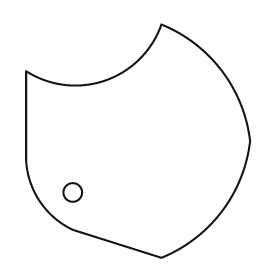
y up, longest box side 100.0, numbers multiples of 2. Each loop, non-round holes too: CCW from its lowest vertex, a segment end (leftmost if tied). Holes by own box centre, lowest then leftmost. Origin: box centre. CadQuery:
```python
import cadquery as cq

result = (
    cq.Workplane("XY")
    .moveTo(10.0, -50.0)
    .threePointArc((36.0, -30.0), (48.0, 0.0))
    .threePointArc((36.0, 30.0), (10.0, 50.0))
    .threePointArc((-14.0, 26.0), (-48.0, 30.0))
    .lineTo(-48.0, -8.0)
    .threePointArc((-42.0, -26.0), (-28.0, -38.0))
    .close()
    .moveTo(-28.0, -22.0)
    .circle(4.0)
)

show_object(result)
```